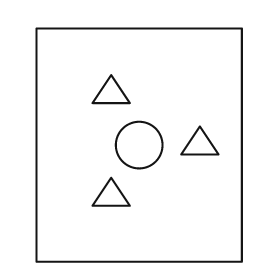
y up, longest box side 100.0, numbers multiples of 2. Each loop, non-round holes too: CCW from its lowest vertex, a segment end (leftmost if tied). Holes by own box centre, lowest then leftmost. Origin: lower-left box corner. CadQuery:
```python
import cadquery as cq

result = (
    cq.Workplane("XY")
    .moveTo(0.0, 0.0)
    .lineTo(88.0, 0.0)
    .lineTo(88.0, 100.0)
    .lineTo(0.0, 100.0)
    .close()
    .moveTo(24.0, 24.0)
    .lineTo(40.0, 24.0)
    .lineTo(32.0, 36.0)
    .close()
    .moveTo(44.0, 50.0)
    .circle(10.0)
    .moveTo(62.0, 46.0)
    .lineTo(78.0, 46.0)
    .lineTo(70.0, 58.0)
    .close()
    .moveTo(24.0, 68.0)
    .lineTo(40.0, 68.0)
    .lineTo(32.0, 80.0)
    .close()
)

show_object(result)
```